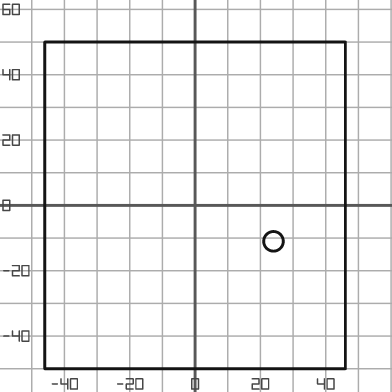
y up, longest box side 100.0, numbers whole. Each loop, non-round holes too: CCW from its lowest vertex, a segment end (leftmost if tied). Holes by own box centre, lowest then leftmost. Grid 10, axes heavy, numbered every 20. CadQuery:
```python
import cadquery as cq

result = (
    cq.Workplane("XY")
    .moveTo(-46.0, -50.0)
    .lineTo(46.0, -50.0)
    .lineTo(46.0, 50.0)
    .lineTo(-46.0, 50.0)
    .close()
    .moveTo(24.0, -11.0)
    .circle(3.0)
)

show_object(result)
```